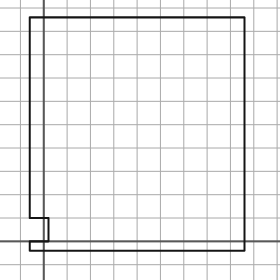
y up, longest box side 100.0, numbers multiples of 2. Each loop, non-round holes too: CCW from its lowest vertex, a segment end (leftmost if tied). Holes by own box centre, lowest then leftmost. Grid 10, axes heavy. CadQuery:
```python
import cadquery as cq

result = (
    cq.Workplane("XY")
    .moveTo(-6.0, -4.0)
    .lineTo(86.0, -4.0)
    .lineTo(86.0, 96.0)
    .lineTo(-6.0, 96.0)
    .lineTo(-6.0, 10.0)
    .lineTo(2.0, 10.0)
    .lineTo(2.0, 0.0)
    .lineTo(-6.0, 0.0)
    .close()
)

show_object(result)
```